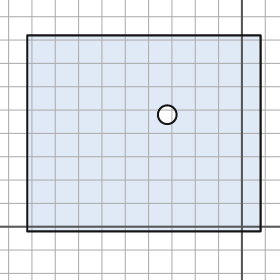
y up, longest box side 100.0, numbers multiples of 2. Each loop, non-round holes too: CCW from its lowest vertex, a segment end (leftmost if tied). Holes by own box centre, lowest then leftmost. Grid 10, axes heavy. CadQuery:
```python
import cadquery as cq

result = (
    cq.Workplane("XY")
    .moveTo(-92.0, -2.0)
    .lineTo(8.0, -2.0)
    .lineTo(8.0, 82.0)
    .lineTo(-92.0, 82.0)
    .close()
    .moveTo(-32.0, 48.0)
    .circle(4.0)
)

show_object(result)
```